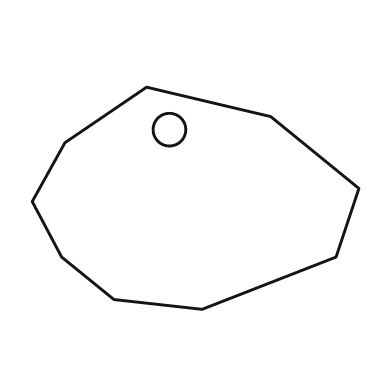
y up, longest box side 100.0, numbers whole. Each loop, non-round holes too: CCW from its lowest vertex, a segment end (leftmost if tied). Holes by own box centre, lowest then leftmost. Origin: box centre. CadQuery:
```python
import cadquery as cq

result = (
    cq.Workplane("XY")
    .moveTo(2.0, -34.0)
    .lineTo(43.0, -18.0)
    .lineTo(50.0, 3.0)
    .lineTo(23.0, 25.0)
    .lineTo(-15.0, 34.0)
    .lineTo(-40.0, 17.0)
    .lineTo(-50.0, -1.0)
    .lineTo(-41.0, -18.0)
    .lineTo(-25.0, -31.0)
    .close()
    .moveTo(-8.0, 21.0)
    .circle(5.0)
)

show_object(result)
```